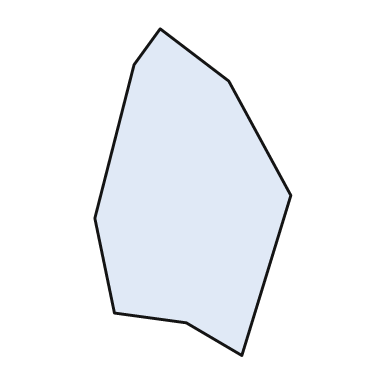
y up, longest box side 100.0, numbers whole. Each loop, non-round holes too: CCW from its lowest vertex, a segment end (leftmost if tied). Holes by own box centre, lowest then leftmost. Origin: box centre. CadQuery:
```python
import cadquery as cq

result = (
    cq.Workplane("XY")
    .moveTo(15.0, -50.0)
    .lineTo(30.0, -1.0)
    .lineTo(11.0, 34.0)
    .lineTo(-10.0, 50.0)
    .lineTo(-18.0, 39.0)
    .lineTo(-30.0, -8.0)
    .lineTo(-24.0, -37.0)
    .lineTo(-2.0, -40.0)
    .close()
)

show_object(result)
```